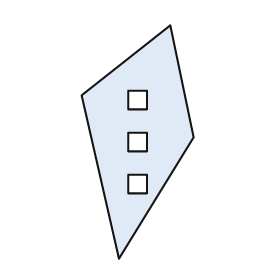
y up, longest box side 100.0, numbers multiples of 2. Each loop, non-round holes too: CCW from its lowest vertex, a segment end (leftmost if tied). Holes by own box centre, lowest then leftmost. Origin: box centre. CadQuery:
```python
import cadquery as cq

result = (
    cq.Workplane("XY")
    .moveTo(-8.0, -50.0)
    .lineTo(24.0, 2.0)
    .lineTo(14.0, 50.0)
    .lineTo(-24.0, 20.0)
    .close()
    .moveTo(-4.0, -22.0)
    .lineTo(4.0, -22.0)
    .lineTo(4.0, -14.0)
    .lineTo(-4.0, -14.0)
    .close()
    .moveTo(-4.0, -4.0)
    .lineTo(4.0, -4.0)
    .lineTo(4.0, 4.0)
    .lineTo(-4.0, 4.0)
    .close()
    .moveTo(-4.0, 14.0)
    .lineTo(4.0, 14.0)
    .lineTo(4.0, 22.0)
    .lineTo(-4.0, 22.0)
    .close()
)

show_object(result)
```